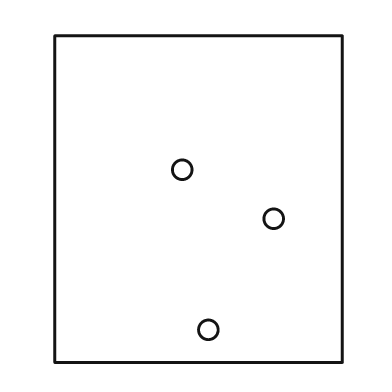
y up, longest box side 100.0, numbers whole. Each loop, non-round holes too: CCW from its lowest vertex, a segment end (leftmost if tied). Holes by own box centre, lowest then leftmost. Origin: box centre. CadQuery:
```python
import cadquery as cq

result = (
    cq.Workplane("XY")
    .moveTo(-44.0, -50.0)
    .lineTo(44.0, -50.0)
    .lineTo(44.0, 50.0)
    .lineTo(-44.0, 50.0)
    .close()
    .moveTo(3.0, -40.0)
    .circle(3.0)
    .moveTo(23.0, -6.0)
    .circle(3.0)
    .moveTo(-5.0, 9.0)
    .circle(3.0)
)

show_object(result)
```